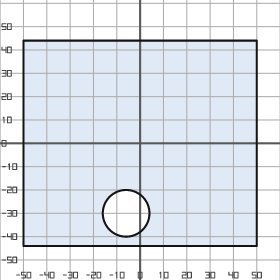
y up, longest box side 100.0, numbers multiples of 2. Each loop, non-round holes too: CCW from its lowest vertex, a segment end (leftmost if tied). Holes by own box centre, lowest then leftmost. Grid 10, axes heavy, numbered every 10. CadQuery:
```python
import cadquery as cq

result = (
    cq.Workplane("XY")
    .moveTo(-50.0, -44.0)
    .lineTo(50.0, -44.0)
    .lineTo(50.0, 44.0)
    .lineTo(-50.0, 44.0)
    .close()
    .moveTo(-6.0, -30.0)
    .circle(10.0)
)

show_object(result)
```